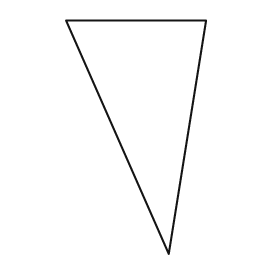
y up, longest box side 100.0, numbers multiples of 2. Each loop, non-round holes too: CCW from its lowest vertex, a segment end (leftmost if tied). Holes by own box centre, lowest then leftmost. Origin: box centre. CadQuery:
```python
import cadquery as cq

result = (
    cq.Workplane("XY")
    .moveTo(14.0, -50.0)
    .lineTo(30.0, 50.0)
    .lineTo(-30.0, 50.0)
    .close()
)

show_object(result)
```